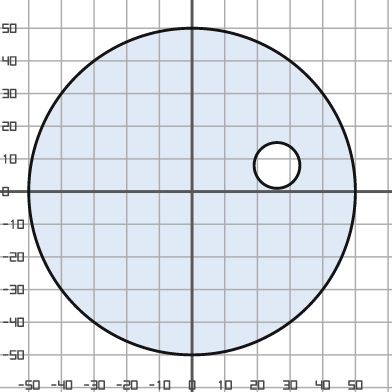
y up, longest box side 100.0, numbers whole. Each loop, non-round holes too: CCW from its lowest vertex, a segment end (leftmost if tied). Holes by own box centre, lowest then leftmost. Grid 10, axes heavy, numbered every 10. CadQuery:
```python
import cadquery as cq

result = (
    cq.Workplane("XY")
    .moveTo(0.0, 0.0)
    .circle(50.0)
    .moveTo(26.0, 8.0)
    .circle(7.0)
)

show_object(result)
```